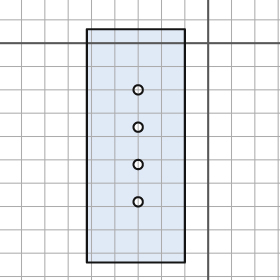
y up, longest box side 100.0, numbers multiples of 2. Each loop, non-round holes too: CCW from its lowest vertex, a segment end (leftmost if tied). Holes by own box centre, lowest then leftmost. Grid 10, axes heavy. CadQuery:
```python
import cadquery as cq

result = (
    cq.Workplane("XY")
    .moveTo(-52.0, -94.0)
    .lineTo(-10.0, -94.0)
    .lineTo(-10.0, 6.0)
    .lineTo(-52.0, 6.0)
    .close()
    .moveTo(-30.0, -68.0)
    .circle(2.0)
    .moveTo(-30.0, -52.0)
    .circle(2.0)
    .moveTo(-30.0, -36.0)
    .circle(2.0)
    .moveTo(-30.0, -20.0)
    .circle(2.0)
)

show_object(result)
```